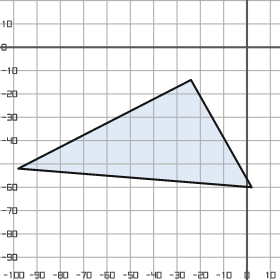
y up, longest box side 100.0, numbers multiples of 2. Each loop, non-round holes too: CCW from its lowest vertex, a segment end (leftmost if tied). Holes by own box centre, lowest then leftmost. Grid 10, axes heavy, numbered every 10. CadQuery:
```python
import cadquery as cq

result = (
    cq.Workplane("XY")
    .moveTo(2.0, -60.0)
    .lineTo(-24.0, -14.0)
    .lineTo(-98.0, -52.0)
    .close()
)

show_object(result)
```